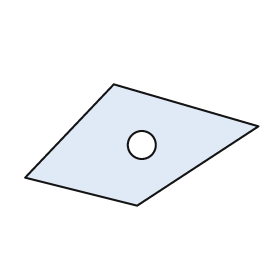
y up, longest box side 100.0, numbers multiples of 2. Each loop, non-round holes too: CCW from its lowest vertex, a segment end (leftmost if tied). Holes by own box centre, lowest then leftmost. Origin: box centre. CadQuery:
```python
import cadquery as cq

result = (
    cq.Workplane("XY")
    .moveTo(-2.0, -26.0)
    .lineTo(50.0, 8.0)
    .lineTo(-12.0, 26.0)
    .lineTo(-50.0, -14.0)
    .close()
    .moveTo(0.0, 0.0)
    .circle(6.0)
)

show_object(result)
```